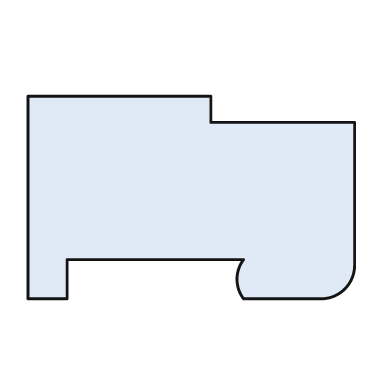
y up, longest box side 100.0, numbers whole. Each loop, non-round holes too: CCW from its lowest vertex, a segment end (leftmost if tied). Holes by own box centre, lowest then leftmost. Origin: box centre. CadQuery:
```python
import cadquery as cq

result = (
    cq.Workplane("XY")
    .moveTo(-50.0, -31.0)
    .lineTo(-38.0, -31.0)
    .lineTo(-38.0, -19.0)
    .lineTo(16.0, -19.0)
    .threePointArc((14.0, -25.0), (16.0, -31.0))
    .lineTo(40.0, -31.0)
    .threePointArc((47.0, -28.0), (50.0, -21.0))
    .lineTo(50.0, 23.0)
    .lineTo(6.0, 23.0)
    .lineTo(6.0, 31.0)
    .lineTo(-50.0, 31.0)
    .close()
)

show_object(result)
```